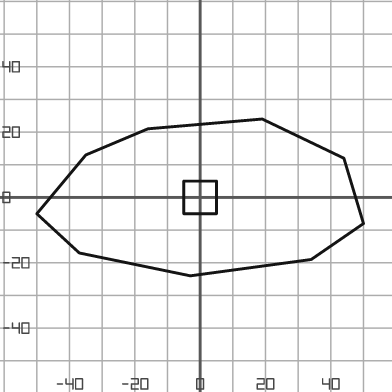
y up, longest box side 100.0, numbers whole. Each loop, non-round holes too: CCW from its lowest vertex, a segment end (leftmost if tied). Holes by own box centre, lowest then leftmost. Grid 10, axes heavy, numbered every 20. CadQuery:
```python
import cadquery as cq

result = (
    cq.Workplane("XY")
    .moveTo(-3.0, -24.0)
    .lineTo(34.0, -19.0)
    .lineTo(50.0, -8.0)
    .lineTo(44.0, 12.0)
    .lineTo(19.0, 24.0)
    .lineTo(-16.0, 21.0)
    .lineTo(-35.0, 13.0)
    .lineTo(-50.0, -5.0)
    .lineTo(-37.0, -17.0)
    .close()
    .moveTo(-5.0, -5.0)
    .lineTo(5.0, -5.0)
    .lineTo(5.0, 5.0)
    .lineTo(-5.0, 5.0)
    .close()
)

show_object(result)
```